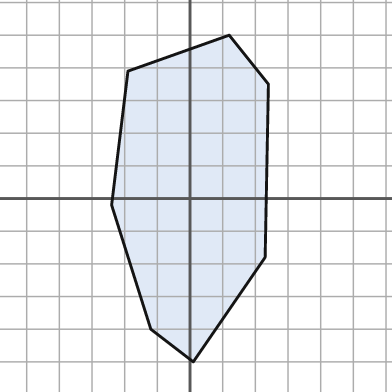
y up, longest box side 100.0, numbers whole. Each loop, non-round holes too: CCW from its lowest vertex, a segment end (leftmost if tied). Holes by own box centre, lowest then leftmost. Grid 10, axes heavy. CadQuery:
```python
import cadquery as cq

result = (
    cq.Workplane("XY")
    .moveTo(1.0, -50.0)
    .lineTo(23.0, -18.0)
    .lineTo(24.0, 35.0)
    .lineTo(12.0, 50.0)
    .lineTo(-19.0, 39.0)
    .lineTo(-24.0, -2.0)
    .lineTo(-12.0, -40.0)
    .close()
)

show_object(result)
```